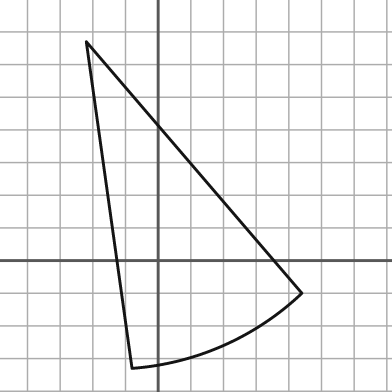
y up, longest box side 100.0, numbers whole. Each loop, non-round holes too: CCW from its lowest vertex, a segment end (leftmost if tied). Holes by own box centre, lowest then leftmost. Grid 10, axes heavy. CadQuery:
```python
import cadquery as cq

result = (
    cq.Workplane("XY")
    .moveTo(-8.0, -33.0)
    .threePointArc((20.0, -26.0), (44.0, -10.0))
    .lineTo(-22.0, 67.0)
    .close()
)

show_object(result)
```